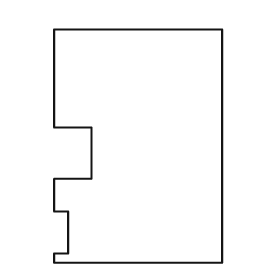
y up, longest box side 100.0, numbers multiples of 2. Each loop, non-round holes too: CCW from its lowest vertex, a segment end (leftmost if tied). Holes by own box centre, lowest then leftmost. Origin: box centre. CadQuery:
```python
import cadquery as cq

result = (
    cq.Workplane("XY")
    .moveTo(-36.0, -50.0)
    .lineTo(36.0, -50.0)
    .lineTo(36.0, 50.0)
    .lineTo(-36.0, 50.0)
    .lineTo(-36.0, 8.0)
    .lineTo(-20.0, 8.0)
    .lineTo(-20.0, -14.0)
    .lineTo(-36.0, -14.0)
    .lineTo(-36.0, -28.0)
    .lineTo(-30.0, -28.0)
    .lineTo(-30.0, -46.0)
    .lineTo(-36.0, -46.0)
    .close()
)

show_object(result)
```